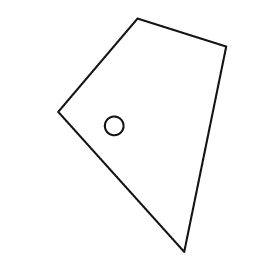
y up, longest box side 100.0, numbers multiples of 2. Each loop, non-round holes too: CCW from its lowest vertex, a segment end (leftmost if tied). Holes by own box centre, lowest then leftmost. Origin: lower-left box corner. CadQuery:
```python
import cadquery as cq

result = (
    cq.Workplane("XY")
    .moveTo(54.0, 0.0)
    .lineTo(72.0, 88.0)
    .lineTo(34.0, 100.0)
    .lineTo(0.0, 60.0)
    .close()
    .moveTo(24.0, 54.0)
    .circle(4.0)
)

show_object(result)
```